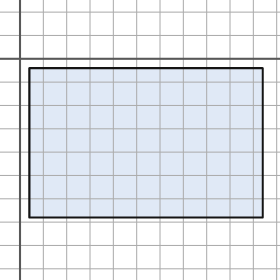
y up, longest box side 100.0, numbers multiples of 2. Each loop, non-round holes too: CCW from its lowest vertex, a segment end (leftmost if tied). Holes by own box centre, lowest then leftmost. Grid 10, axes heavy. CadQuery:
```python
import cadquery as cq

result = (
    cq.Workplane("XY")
    .moveTo(4.0, -68.0)
    .lineTo(104.0, -68.0)
    .lineTo(104.0, -4.0)
    .lineTo(4.0, -4.0)
    .close()
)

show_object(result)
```